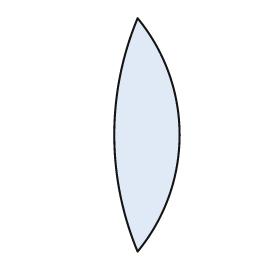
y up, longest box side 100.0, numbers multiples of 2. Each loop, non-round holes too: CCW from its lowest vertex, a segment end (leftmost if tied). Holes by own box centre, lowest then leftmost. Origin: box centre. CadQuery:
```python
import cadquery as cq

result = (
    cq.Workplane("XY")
    .moveTo(-4.0, -50.0)
    .threePointArc((14.0, 0.0), (-4.0, 50.0))
    .threePointArc((-14.0, 0.0), (-4.0, -50.0))
    .close()
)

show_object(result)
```